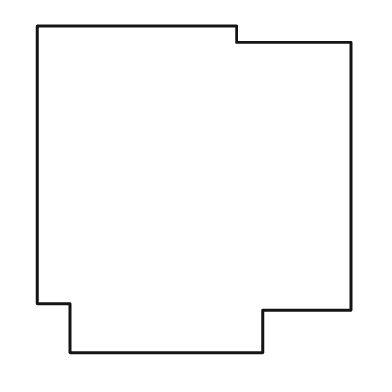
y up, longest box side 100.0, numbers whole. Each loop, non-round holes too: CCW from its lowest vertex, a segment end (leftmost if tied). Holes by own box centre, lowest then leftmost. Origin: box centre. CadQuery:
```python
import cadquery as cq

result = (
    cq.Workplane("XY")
    .moveTo(-38.0, -50.0)
    .lineTo(21.0, -50.0)
    .lineTo(21.0, -37.0)
    .lineTo(48.0, -37.0)
    .lineTo(48.0, 45.0)
    .lineTo(13.0, 45.0)
    .lineTo(13.0, 50.0)
    .lineTo(-48.0, 50.0)
    .lineTo(-48.0, -35.0)
    .lineTo(-38.0, -35.0)
    .close()
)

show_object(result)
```